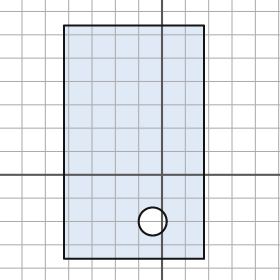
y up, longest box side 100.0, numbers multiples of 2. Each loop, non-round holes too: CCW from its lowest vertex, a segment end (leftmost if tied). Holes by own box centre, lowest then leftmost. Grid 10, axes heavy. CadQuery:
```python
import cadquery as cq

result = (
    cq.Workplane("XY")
    .moveTo(-42.0, -36.0)
    .lineTo(18.0, -36.0)
    .lineTo(18.0, 64.0)
    .lineTo(-42.0, 64.0)
    .close()
    .moveTo(-4.0, -20.0)
    .circle(6.0)
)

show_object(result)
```